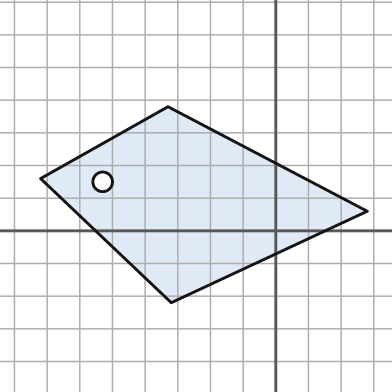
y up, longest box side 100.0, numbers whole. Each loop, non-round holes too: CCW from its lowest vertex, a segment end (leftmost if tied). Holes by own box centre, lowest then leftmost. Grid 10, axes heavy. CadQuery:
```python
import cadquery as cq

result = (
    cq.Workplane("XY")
    .moveTo(-32.0, -22.0)
    .lineTo(28.0, 6.0)
    .lineTo(-33.0, 38.0)
    .lineTo(-72.0, 16.0)
    .close()
    .moveTo(-53.0, 15.0)
    .circle(3.0)
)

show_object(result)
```